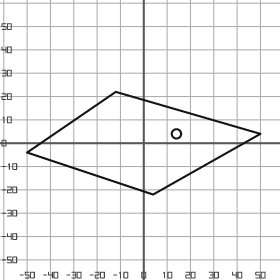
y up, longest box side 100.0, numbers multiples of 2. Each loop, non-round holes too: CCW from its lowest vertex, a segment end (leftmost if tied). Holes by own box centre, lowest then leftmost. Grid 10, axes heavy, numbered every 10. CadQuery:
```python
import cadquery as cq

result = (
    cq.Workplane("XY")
    .moveTo(4.0, -22.0)
    .lineTo(50.0, 4.0)
    .lineTo(-12.0, 22.0)
    .lineTo(-50.0, -4.0)
    .close()
    .moveTo(14.0, 4.0)
    .circle(2.0)
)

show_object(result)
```